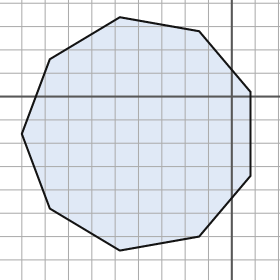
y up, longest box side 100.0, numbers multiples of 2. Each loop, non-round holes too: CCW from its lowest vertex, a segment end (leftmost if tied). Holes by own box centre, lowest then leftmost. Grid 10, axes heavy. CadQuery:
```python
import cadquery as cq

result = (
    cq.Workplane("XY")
    .moveTo(-48.0, -66.0)
    .lineTo(-14.0, -60.0)
    .lineTo(8.0, -34.0)
    .lineTo(8.0, 2.0)
    .lineTo(-14.0, 28.0)
    .lineTo(-48.0, 34.0)
    .lineTo(-78.0, 16.0)
    .lineTo(-90.0, -16.0)
    .lineTo(-78.0, -48.0)
    .close()
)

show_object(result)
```